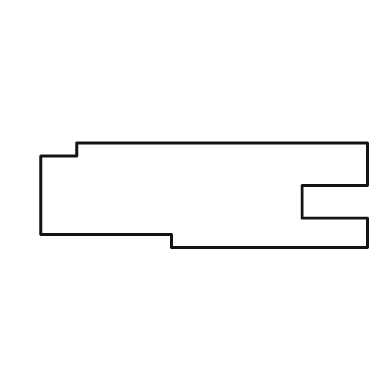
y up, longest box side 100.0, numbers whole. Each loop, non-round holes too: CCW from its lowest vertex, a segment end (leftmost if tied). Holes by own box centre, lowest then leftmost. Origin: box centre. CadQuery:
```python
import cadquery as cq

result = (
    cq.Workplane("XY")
    .moveTo(-10.0, -16.0)
    .lineTo(50.0, -16.0)
    .lineTo(50.0, -7.0)
    .lineTo(30.0, -7.0)
    .lineTo(30.0, 3.0)
    .lineTo(50.0, 3.0)
    .lineTo(50.0, 16.0)
    .lineTo(-39.0, 16.0)
    .lineTo(-39.0, 12.0)
    .lineTo(-50.0, 12.0)
    .lineTo(-50.0, -12.0)
    .lineTo(-10.0, -12.0)
    .close()
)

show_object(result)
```